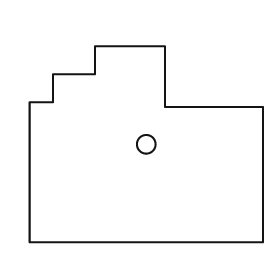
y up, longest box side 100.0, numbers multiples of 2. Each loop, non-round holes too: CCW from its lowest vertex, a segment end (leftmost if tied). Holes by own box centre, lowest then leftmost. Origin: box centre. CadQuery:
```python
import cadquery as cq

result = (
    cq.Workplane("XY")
    .moveTo(-50.0, -42.0)
    .lineTo(50.0, -42.0)
    .lineTo(50.0, 16.0)
    .lineTo(8.0, 16.0)
    .lineTo(8.0, 42.0)
    .lineTo(-22.0, 42.0)
    .lineTo(-22.0, 30.0)
    .lineTo(-40.0, 30.0)
    .lineTo(-40.0, 18.0)
    .lineTo(-50.0, 18.0)
    .close()
    .moveTo(0.0, 0.0)
    .circle(4.0)
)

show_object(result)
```